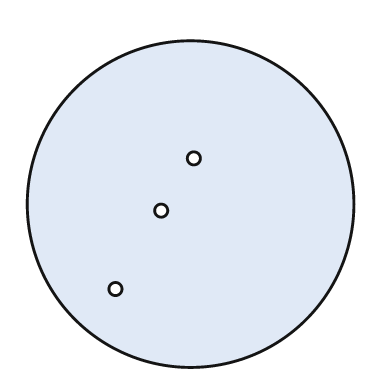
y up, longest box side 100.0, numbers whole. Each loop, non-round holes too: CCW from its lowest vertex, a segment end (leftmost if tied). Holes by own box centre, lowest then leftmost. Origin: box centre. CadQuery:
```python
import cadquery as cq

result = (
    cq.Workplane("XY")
    .moveTo(0.0, 0.0)
    .circle(50.0)
    .moveTo(-23.0, -26.0)
    .circle(2.0)
    .moveTo(-9.0, -2.0)
    .circle(2.0)
    .moveTo(1.0, 14.0)
    .circle(2.0)
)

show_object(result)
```